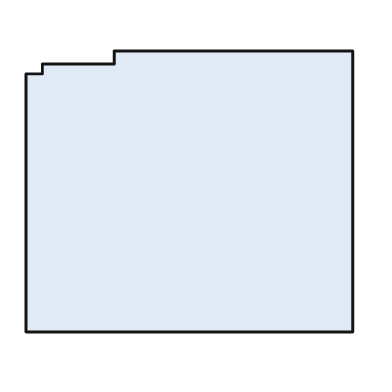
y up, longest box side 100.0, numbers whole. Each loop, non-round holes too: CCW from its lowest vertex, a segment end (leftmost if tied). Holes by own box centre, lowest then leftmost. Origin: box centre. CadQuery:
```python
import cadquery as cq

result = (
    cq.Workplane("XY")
    .moveTo(-50.0, -43.0)
    .lineTo(50.0, -43.0)
    .lineTo(50.0, 43.0)
    .lineTo(-23.0, 43.0)
    .lineTo(-23.0, 39.0)
    .lineTo(-45.0, 39.0)
    .lineTo(-45.0, 36.0)
    .lineTo(-50.0, 36.0)
    .close()
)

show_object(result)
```